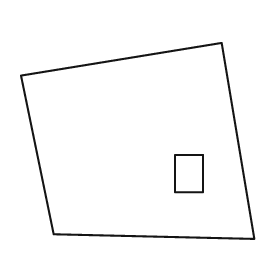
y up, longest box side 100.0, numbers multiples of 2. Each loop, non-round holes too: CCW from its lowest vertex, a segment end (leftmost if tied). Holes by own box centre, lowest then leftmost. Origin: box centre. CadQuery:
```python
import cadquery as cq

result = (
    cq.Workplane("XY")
    .moveTo(50.0, -42.0)
    .lineTo(36.0, 42.0)
    .lineTo(-50.0, 28.0)
    .lineTo(-36.0, -40.0)
    .close()
    .moveTo(16.0, -22.0)
    .lineTo(28.0, -22.0)
    .lineTo(28.0, -6.0)
    .lineTo(16.0, -6.0)
    .close()
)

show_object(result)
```